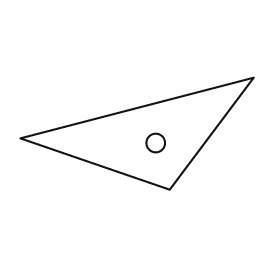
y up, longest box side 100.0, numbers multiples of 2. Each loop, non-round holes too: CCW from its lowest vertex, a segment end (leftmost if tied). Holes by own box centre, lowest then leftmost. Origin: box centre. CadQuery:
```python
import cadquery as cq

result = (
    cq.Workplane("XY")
    .moveTo(14.0, -24.0)
    .lineTo(50.0, 24.0)
    .lineTo(-50.0, -2.0)
    .close()
    .moveTo(8.0, -4.0)
    .circle(4.0)
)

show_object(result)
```